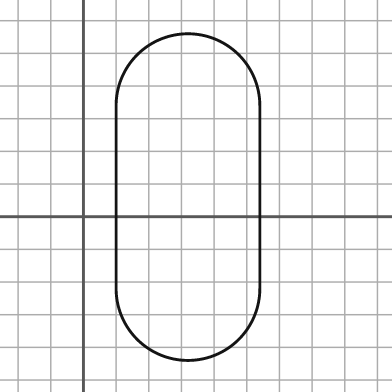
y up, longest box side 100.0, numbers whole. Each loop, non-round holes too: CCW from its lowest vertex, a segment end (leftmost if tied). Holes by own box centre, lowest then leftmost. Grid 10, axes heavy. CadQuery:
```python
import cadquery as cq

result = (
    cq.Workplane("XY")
    .moveTo(10.0, -22.0)
    .threePointArc((32.0, -44.0), (54.0, -22.0))
    .lineTo(54.0, 34.0)
    .threePointArc((32.0, 56.0), (10.0, 34.0))
    .close()
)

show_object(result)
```